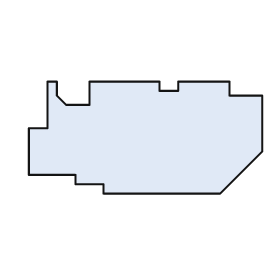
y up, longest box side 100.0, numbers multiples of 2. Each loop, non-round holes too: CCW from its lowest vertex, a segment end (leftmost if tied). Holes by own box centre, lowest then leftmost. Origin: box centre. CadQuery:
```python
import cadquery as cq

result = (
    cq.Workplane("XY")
    .moveTo(-18.0, -24.0)
    .lineTo(32.0, -24.0)
    .lineTo(50.0, -6.0)
    .lineTo(50.0, 18.0)
    .lineTo(36.0, 18.0)
    .lineTo(36.0, 24.0)
    .lineTo(14.0, 24.0)
    .lineTo(14.0, 20.0)
    .lineTo(6.0, 20.0)
    .lineTo(6.0, 24.0)
    .lineTo(-24.0, 24.0)
    .lineTo(-24.0, 14.0)
    .lineTo(-34.0, 14.0)
    .lineTo(-38.0, 18.0)
    .lineTo(-38.0, 24.0)
    .lineTo(-42.0, 24.0)
    .lineTo(-42.0, 4.0)
    .lineTo(-50.0, 4.0)
    .lineTo(-50.0, -16.0)
    .lineTo(-30.0, -16.0)
    .lineTo(-30.0, -20.0)
    .lineTo(-18.0, -20.0)
    .close()
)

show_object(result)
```